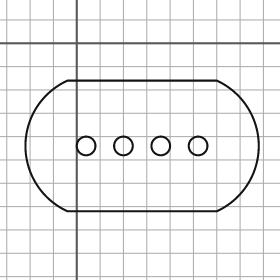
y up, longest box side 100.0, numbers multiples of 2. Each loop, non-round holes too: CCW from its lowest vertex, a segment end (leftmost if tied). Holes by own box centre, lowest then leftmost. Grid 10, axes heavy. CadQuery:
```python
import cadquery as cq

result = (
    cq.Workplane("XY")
    .moveTo(-4.0, -72.0)
    .lineTo(60.0, -72.0)
    .threePointArc((78.0, -44.0), (60.0, -16.0))
    .lineTo(-4.0, -16.0)
    .threePointArc((-22.0, -44.0), (-4.0, -72.0))
    .close()
    .moveTo(4.0, -44.0)
    .circle(4.0)
    .moveTo(20.0, -44.0)
    .circle(4.0)
    .moveTo(36.0, -44.0)
    .circle(4.0)
    .moveTo(52.0, -44.0)
    .circle(4.0)
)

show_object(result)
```